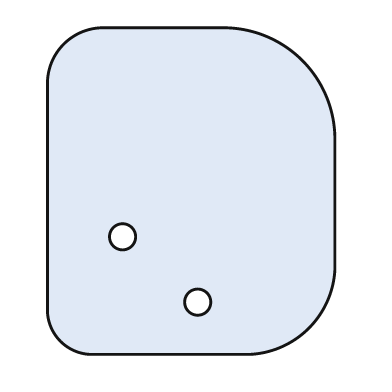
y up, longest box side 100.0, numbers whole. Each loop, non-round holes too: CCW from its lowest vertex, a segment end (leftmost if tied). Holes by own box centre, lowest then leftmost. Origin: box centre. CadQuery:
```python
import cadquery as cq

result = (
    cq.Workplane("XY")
    .moveTo(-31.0, -50.0)
    .lineTo(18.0, -50.0)
    .threePointArc((36.0, -42.0), (44.0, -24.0))
    .lineTo(44.0, 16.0)
    .threePointArc((34.0, 40.0), (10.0, 50.0))
    .lineTo(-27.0, 50.0)
    .threePointArc((-39.0, 45.0), (-44.0, 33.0))
    .lineTo(-44.0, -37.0)
    .threePointArc((-40.0, -46.0), (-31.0, -50.0))
    .close()
    .moveTo(2.0, -34.0)
    .circle(4.0)
    .moveTo(-21.0, -14.0)
    .circle(4.0)
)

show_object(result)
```